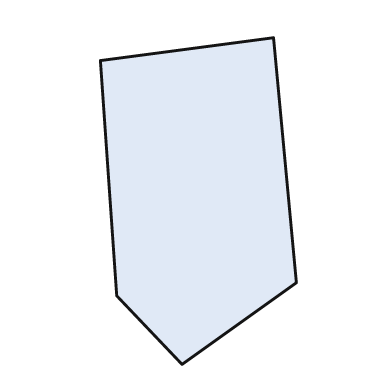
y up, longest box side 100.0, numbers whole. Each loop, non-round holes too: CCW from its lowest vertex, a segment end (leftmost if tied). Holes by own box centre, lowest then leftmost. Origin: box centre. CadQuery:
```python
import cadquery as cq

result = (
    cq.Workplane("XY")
    .moveTo(-5.0, -50.0)
    .lineTo(30.0, -25.0)
    .lineTo(23.0, 50.0)
    .lineTo(-30.0, 43.0)
    .lineTo(-25.0, -29.0)
    .close()
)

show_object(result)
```